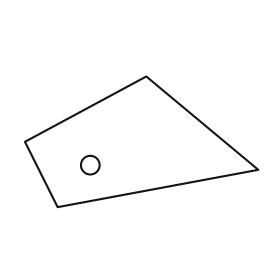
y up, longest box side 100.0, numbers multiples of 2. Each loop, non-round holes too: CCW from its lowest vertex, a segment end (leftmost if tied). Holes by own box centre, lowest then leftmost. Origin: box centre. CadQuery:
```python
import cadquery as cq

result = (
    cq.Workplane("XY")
    .moveTo(-36.0, -28.0)
    .lineTo(50.0, -12.0)
    .lineTo(2.0, 28.0)
    .lineTo(-50.0, 0.0)
    .close()
    .moveTo(-22.0, -10.0)
    .circle(4.0)
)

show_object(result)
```